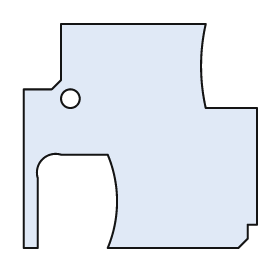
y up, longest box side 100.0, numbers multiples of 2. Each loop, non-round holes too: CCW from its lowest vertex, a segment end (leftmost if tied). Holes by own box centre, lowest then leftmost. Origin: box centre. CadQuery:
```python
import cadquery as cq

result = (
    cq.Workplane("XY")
    .moveTo(-50.0, -48.0)
    .lineTo(-44.0, -48.0)
    .lineTo(-44.0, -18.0)
    .threePointArc((-42.0, -10.0), (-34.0, -8.0))
    .lineTo(-14.0, -8.0)
    .threePointArc((-10.0, -28.0), (-14.0, -48.0))
    .lineTo(42.0, -48.0)
    .lineTo(46.0, -44.0)
    .lineTo(46.0, -38.0)
    .lineTo(50.0, -38.0)
    .lineTo(50.0, 12.0)
    .lineTo(28.0, 12.0)
    .threePointArc((26.0, 30.0), (28.0, 48.0))
    .lineTo(-34.0, 48.0)
    .lineTo(-34.0, 24.0)
    .lineTo(-38.0, 20.0)
    .lineTo(-50.0, 20.0)
    .close()
    .moveTo(-30.0, 16.0)
    .circle(4.0)
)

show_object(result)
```